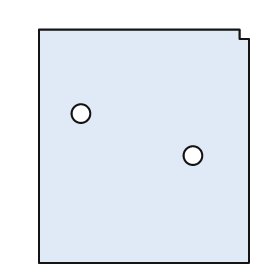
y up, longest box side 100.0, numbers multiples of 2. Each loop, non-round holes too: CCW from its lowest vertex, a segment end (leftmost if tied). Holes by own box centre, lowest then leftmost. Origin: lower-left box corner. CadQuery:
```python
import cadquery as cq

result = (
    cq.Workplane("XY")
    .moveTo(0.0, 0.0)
    .lineTo(90.0, 0.0)
    .lineTo(90.0, 96.0)
    .lineTo(86.0, 96.0)
    .lineTo(86.0, 100.0)
    .lineTo(0.0, 100.0)
    .close()
    .moveTo(66.0, 46.0)
    .circle(4.0)
    .moveTo(18.0, 64.0)
    .circle(4.0)
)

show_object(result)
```